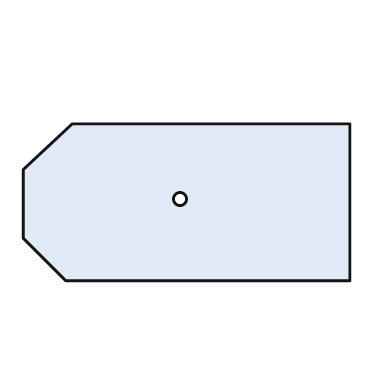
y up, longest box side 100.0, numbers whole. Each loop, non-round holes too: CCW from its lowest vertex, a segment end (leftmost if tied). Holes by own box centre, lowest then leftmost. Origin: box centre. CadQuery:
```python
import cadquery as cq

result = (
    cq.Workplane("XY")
    .moveTo(-37.0, -24.0)
    .lineTo(50.0, -24.0)
    .lineTo(50.0, 24.0)
    .lineTo(-35.0, 24.0)
    .lineTo(-50.0, 10.0)
    .lineTo(-50.0, -11.0)
    .close()
    .moveTo(-2.0, 1.0)
    .circle(2.0)
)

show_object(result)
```